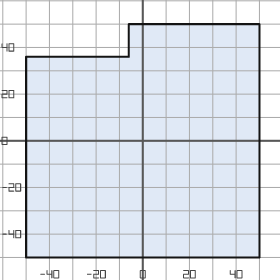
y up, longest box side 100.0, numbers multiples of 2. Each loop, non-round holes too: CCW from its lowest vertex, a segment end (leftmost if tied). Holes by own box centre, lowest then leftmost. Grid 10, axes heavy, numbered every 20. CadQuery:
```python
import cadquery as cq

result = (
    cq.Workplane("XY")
    .moveTo(-50.0, -50.0)
    .lineTo(50.0, -50.0)
    .lineTo(50.0, 50.0)
    .lineTo(-6.0, 50.0)
    .lineTo(-6.0, 36.0)
    .lineTo(-50.0, 36.0)
    .close()
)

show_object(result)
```